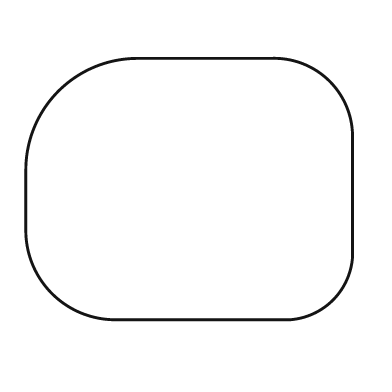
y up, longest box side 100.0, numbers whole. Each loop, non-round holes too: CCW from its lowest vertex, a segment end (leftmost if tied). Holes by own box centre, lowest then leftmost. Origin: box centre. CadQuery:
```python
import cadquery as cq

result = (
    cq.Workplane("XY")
    .moveTo(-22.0, -40.0)
    .lineTo(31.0, -40.0)
    .threePointArc((44.0, -34.0), (50.0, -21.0))
    .lineTo(50.0, 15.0)
    .threePointArc((43.0, 33.0), (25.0, 40.0))
    .lineTo(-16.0, 40.0)
    .threePointArc((-40.0, 30.0), (-50.0, 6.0))
    .lineTo(-50.0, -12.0)
    .threePointArc((-42.0, -32.0), (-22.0, -40.0))
    .close()
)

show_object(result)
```